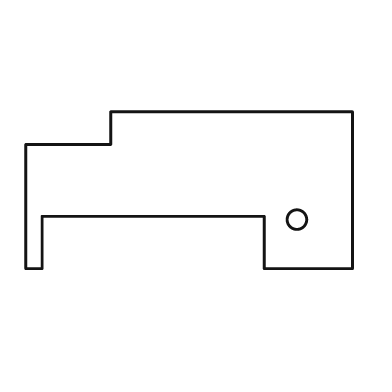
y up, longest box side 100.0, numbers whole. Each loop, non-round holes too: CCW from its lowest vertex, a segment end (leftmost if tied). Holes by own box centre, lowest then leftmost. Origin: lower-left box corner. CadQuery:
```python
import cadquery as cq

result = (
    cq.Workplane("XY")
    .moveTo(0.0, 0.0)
    .lineTo(5.0, 0.0)
    .lineTo(5.0, 16.0)
    .lineTo(73.0, 16.0)
    .lineTo(73.0, 0.0)
    .lineTo(100.0, 0.0)
    .lineTo(100.0, 48.0)
    .lineTo(26.0, 48.0)
    .lineTo(26.0, 38.0)
    .lineTo(0.0, 38.0)
    .close()
    .moveTo(83.0, 15.0)
    .circle(3.0)
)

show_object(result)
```